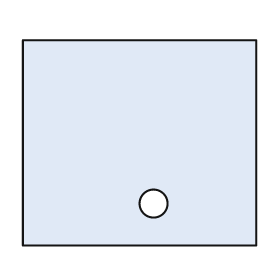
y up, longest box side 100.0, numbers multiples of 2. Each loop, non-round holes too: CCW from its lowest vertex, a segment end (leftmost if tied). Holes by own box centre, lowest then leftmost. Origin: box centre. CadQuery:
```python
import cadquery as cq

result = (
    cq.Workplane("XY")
    .moveTo(-50.0, -44.0)
    .lineTo(50.0, -44.0)
    .lineTo(50.0, 44.0)
    .lineTo(-50.0, 44.0)
    .close()
    .moveTo(6.0, -26.0)
    .circle(6.0)
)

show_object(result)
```